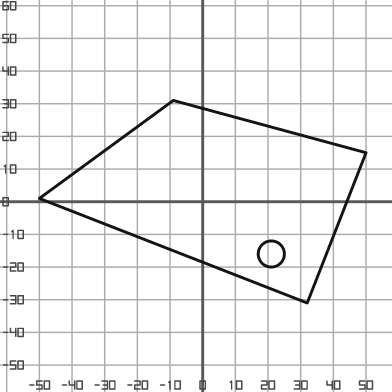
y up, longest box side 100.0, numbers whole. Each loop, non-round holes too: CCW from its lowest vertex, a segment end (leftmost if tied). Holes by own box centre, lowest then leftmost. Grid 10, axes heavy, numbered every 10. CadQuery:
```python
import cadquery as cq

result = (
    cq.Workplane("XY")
    .moveTo(32.0, -31.0)
    .lineTo(50.0, 15.0)
    .lineTo(-9.0, 31.0)
    .lineTo(-50.0, 1.0)
    .close()
    .moveTo(21.0, -16.0)
    .circle(4.0)
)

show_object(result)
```